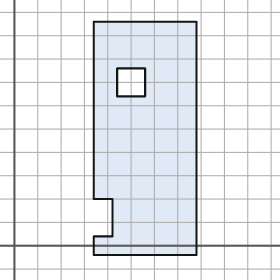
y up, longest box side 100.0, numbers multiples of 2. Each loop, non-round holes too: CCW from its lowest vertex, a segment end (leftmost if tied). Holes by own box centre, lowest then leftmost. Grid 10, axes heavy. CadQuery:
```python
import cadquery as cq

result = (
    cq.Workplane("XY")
    .moveTo(34.0, -4.0)
    .lineTo(78.0, -4.0)
    .lineTo(78.0, 96.0)
    .lineTo(34.0, 96.0)
    .lineTo(34.0, 20.0)
    .lineTo(42.0, 20.0)
    .lineTo(42.0, 4.0)
    .lineTo(34.0, 4.0)
    .close()
    .moveTo(44.0, 64.0)
    .lineTo(56.0, 64.0)
    .lineTo(56.0, 76.0)
    .lineTo(44.0, 76.0)
    .close()
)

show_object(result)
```